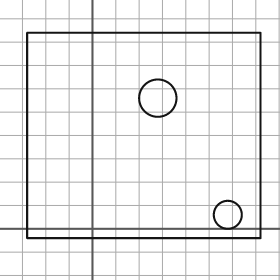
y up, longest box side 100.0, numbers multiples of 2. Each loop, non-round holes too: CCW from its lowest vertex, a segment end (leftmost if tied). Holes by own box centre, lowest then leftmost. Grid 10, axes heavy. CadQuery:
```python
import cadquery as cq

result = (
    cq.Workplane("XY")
    .moveTo(-28.0, -4.0)
    .lineTo(72.0, -4.0)
    .lineTo(72.0, 84.0)
    .lineTo(-28.0, 84.0)
    .close()
    .moveTo(58.0, 6.0)
    .circle(6.0)
    .moveTo(28.0, 56.0)
    .circle(8.0)
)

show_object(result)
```